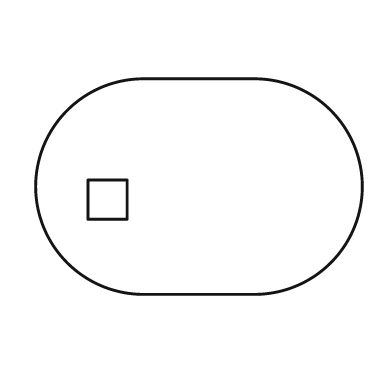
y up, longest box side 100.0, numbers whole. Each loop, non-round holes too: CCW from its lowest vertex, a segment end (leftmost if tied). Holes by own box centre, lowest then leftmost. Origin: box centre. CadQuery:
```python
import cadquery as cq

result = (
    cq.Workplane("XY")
    .moveTo(-17.0, -33.0)
    .lineTo(17.0, -33.0)
    .threePointArc((50.0, 0.0), (17.0, 33.0))
    .lineTo(-17.0, 33.0)
    .threePointArc((-50.0, 0.0), (-17.0, -33.0))
    .close()
    .moveTo(-34.0, -10.0)
    .lineTo(-22.0, -10.0)
    .lineTo(-22.0, 2.0)
    .lineTo(-34.0, 2.0)
    .close()
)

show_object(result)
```